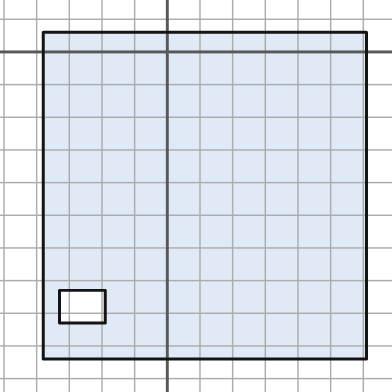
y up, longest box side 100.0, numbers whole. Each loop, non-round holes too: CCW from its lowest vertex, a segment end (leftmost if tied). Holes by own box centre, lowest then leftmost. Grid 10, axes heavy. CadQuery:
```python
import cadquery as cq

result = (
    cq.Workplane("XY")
    .moveTo(-38.0, -94.0)
    .lineTo(61.0, -94.0)
    .lineTo(61.0, 6.0)
    .lineTo(-38.0, 6.0)
    .close()
    .moveTo(-33.0, -83.0)
    .lineTo(-19.0, -83.0)
    .lineTo(-19.0, -73.0)
    .lineTo(-33.0, -73.0)
    .close()
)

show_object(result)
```